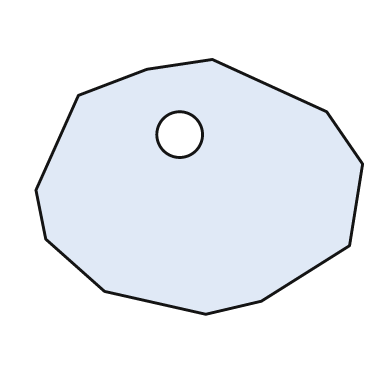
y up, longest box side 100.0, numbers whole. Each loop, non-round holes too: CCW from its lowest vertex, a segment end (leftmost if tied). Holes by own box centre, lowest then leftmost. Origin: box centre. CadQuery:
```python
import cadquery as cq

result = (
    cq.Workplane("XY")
    .moveTo(2.0, -39.0)
    .lineTo(19.0, -35.0)
    .lineTo(46.0, -18.0)
    .lineTo(50.0, 7.0)
    .lineTo(39.0, 23.0)
    .lineTo(4.0, 39.0)
    .lineTo(-16.0, 36.0)
    .lineTo(-37.0, 28.0)
    .lineTo(-50.0, -1.0)
    .lineTo(-47.0, -16.0)
    .lineTo(-29.0, -32.0)
    .close()
    .moveTo(-6.0, 16.0)
    .circle(7.0)
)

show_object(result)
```